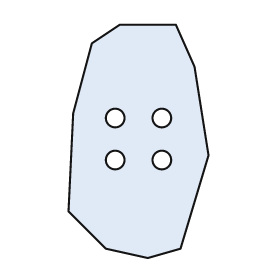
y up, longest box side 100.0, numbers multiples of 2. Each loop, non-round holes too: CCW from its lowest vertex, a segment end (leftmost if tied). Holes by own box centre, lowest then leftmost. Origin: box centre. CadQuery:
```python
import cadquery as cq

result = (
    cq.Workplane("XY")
    .moveTo(4.0, -50.0)
    .lineTo(18.0, -46.0)
    .lineTo(30.0, -6.0)
    .lineTo(24.0, 32.0)
    .lineTo(16.0, 50.0)
    .lineTo(-8.0, 50.0)
    .lineTo(-20.0, 42.0)
    .lineTo(-28.0, 12.0)
    .lineTo(-30.0, -30.0)
    .lineTo(-14.0, -46.0)
    .close()
    .moveTo(-10.0, -8.0)
    .circle(4.0)
    .moveTo(10.0, -8.0)
    .circle(4.0)
    .moveTo(-10.0, 10.0)
    .circle(4.0)
    .moveTo(10.0, 10.0)
    .circle(4.0)
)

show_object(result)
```